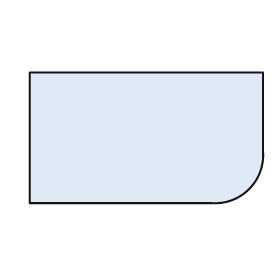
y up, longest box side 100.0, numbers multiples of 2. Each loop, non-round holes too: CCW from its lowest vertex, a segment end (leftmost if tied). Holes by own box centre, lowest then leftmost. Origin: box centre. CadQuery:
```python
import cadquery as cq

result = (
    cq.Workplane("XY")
    .moveTo(-50.0, -28.0)
    .lineTo(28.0, -28.0)
    .threePointArc((44.0, -22.0), (50.0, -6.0))
    .lineTo(50.0, 28.0)
    .lineTo(-50.0, 28.0)
    .close()
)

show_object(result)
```